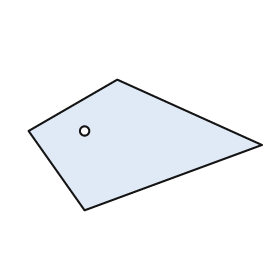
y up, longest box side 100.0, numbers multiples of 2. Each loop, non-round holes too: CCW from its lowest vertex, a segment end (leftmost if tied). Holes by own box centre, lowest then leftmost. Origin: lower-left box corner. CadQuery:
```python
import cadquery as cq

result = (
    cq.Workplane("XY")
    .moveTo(24.0, 0.0)
    .lineTo(100.0, 28.0)
    .lineTo(38.0, 56.0)
    .lineTo(0.0, 34.0)
    .close()
    .moveTo(24.0, 34.0)
    .circle(2.0)
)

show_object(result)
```